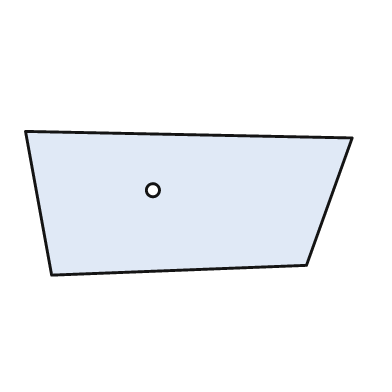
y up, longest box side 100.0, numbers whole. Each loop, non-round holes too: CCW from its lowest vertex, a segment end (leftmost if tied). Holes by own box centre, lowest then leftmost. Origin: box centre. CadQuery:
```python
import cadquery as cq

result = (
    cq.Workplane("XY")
    .moveTo(-42.0, -22.0)
    .lineTo(36.0, -19.0)
    .lineTo(50.0, 20.0)
    .lineTo(-50.0, 22.0)
    .close()
    .moveTo(-11.0, 4.0)
    .circle(2.0)
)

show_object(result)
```